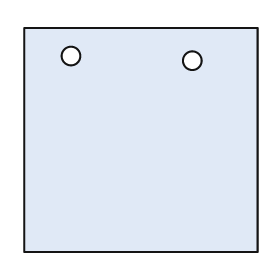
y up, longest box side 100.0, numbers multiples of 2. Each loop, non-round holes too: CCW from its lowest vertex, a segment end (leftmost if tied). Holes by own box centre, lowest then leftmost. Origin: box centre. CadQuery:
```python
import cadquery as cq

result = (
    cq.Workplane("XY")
    .moveTo(-50.0, -48.0)
    .lineTo(50.0, -48.0)
    .lineTo(50.0, 48.0)
    .lineTo(-50.0, 48.0)
    .close()
    .moveTo(22.0, 34.0)
    .circle(4.0)
    .moveTo(-30.0, 36.0)
    .circle(4.0)
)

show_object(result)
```